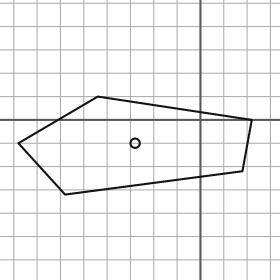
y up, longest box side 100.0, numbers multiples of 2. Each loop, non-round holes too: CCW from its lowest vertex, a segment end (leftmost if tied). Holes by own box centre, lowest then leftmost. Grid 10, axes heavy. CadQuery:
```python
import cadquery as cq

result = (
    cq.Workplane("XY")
    .moveTo(-58.0, -32.0)
    .lineTo(18.0, -22.0)
    .lineTo(22.0, 0.0)
    .lineTo(-44.0, 10.0)
    .lineTo(-78.0, -10.0)
    .close()
    .moveTo(-28.0, -10.0)
    .circle(2.0)
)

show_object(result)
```